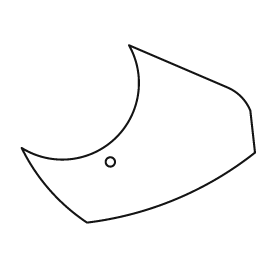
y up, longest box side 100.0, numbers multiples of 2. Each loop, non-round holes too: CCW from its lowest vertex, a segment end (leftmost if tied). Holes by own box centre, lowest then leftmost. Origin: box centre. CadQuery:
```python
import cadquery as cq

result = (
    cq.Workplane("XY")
    .moveTo(-22.0, -38.0)
    .threePointArc((16.0, -28.0), (50.0, -8.0))
    .lineTo(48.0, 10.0)
    .threePointArc((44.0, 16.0), (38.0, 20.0))
    .lineTo(-4.0, 38.0)
    .threePointArc((-10.0, -2.0), (-50.0, -6.0))
    .threePointArc((-38.0, -24.0), (-22.0, -38.0))
    .close()
    .moveTo(-12.0, -12.0)
    .circle(2.0)
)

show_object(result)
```